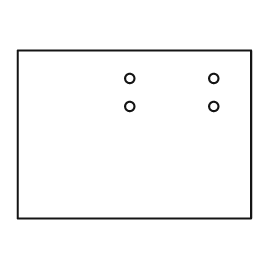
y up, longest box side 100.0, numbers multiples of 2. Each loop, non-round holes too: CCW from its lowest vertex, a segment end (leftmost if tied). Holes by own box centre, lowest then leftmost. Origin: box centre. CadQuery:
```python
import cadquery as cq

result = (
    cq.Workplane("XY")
    .moveTo(-50.0, -36.0)
    .lineTo(50.0, -36.0)
    .lineTo(50.0, 36.0)
    .lineTo(-50.0, 36.0)
    .close()
    .moveTo(-2.0, 12.0)
    .circle(2.0)
    .moveTo(34.0, 12.0)
    .circle(2.0)
    .moveTo(-2.0, 24.0)
    .circle(2.0)
    .moveTo(34.0, 24.0)
    .circle(2.0)
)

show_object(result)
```